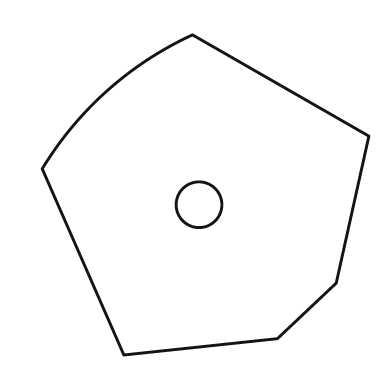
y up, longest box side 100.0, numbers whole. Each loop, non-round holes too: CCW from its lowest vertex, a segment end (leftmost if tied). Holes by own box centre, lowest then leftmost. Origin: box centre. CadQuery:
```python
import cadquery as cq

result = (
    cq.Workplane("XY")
    .moveTo(-25.0, -49.0)
    .lineTo(22.0, -44.0)
    .lineTo(40.0, -27.0)
    .lineTo(50.0, 18.0)
    .lineTo(-4.0, 49.0)
    .threePointArc((-30.0, 32.0), (-50.0, 8.0))
    .close()
    .moveTo(-2.0, -3.0)
    .circle(7.0)
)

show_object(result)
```